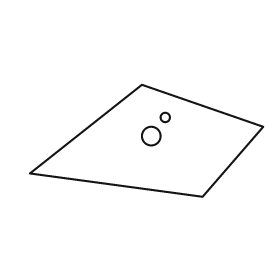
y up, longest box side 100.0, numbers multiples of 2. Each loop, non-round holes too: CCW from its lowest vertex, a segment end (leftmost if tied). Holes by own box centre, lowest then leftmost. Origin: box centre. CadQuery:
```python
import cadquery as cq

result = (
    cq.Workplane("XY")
    .moveTo(24.0, -24.0)
    .lineTo(50.0, 6.0)
    .lineTo(-2.0, 24.0)
    .lineTo(-50.0, -14.0)
    .close()
    .moveTo(2.0, 2.0)
    .circle(4.0)
    .moveTo(8.0, 10.0)
    .circle(2.0)
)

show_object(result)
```